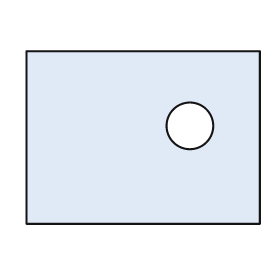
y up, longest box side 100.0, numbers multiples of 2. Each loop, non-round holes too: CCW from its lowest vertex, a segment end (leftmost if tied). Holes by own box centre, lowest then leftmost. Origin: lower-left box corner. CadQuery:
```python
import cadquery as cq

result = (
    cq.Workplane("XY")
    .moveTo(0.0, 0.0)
    .lineTo(100.0, 0.0)
    .lineTo(100.0, 74.0)
    .lineTo(0.0, 74.0)
    .close()
    .moveTo(70.0, 42.0)
    .circle(10.0)
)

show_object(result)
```